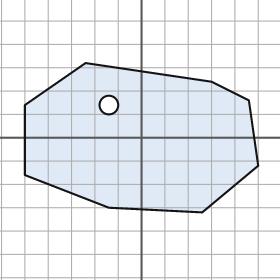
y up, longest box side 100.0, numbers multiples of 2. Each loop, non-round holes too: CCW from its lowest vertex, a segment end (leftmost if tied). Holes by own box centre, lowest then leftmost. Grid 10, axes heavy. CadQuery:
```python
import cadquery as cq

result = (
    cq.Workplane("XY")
    .moveTo(26.0, -32.0)
    .lineTo(50.0, -12.0)
    .lineTo(46.0, 16.0)
    .lineTo(30.0, 24.0)
    .lineTo(-24.0, 32.0)
    .lineTo(-50.0, 14.0)
    .lineTo(-50.0, -16.0)
    .lineTo(-14.0, -30.0)
    .close()
    .moveTo(-14.0, 14.0)
    .circle(4.0)
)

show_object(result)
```